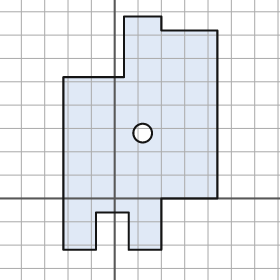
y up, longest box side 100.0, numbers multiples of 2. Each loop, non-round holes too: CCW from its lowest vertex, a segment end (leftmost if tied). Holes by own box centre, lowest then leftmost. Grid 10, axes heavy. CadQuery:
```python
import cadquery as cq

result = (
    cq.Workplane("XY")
    .moveTo(-22.0, -22.0)
    .lineTo(-8.0, -22.0)
    .lineTo(-8.0, -6.0)
    .lineTo(6.0, -6.0)
    .lineTo(6.0, -22.0)
    .lineTo(20.0, -22.0)
    .lineTo(20.0, 0.0)
    .lineTo(44.0, 0.0)
    .lineTo(44.0, 72.0)
    .lineTo(20.0, 72.0)
    .lineTo(20.0, 78.0)
    .lineTo(4.0, 78.0)
    .lineTo(4.0, 52.0)
    .lineTo(-22.0, 52.0)
    .close()
    .moveTo(12.0, 28.0)
    .circle(4.0)
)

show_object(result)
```